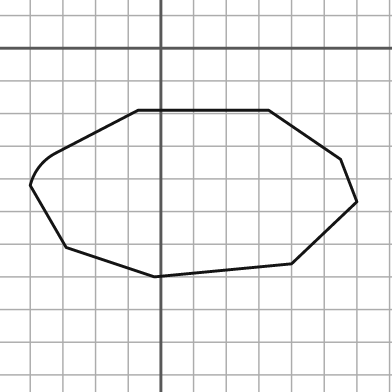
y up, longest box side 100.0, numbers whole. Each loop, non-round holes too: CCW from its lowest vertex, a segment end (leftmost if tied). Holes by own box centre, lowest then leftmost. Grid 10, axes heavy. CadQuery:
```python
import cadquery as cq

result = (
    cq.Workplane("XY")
    .moveTo(-2.0, -70.0)
    .lineTo(40.0, -66.0)
    .lineTo(60.0, -47.0)
    .lineTo(55.0, -34.0)
    .lineTo(33.0, -19.0)
    .lineTo(-7.0, -19.0)
    .lineTo(-32.0, -32.0)
    .threePointArc((-37.0, -36.0), (-40.0, -42.0))
    .lineTo(-29.0, -61.0)
    .close()
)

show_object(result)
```